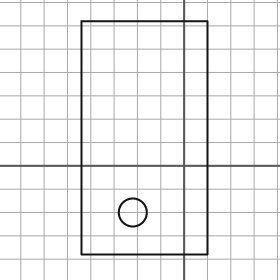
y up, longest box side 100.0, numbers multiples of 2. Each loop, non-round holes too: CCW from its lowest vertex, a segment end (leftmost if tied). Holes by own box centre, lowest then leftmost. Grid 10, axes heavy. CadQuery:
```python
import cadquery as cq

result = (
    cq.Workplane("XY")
    .moveTo(-44.0, -38.0)
    .lineTo(10.0, -38.0)
    .lineTo(10.0, 62.0)
    .lineTo(-44.0, 62.0)
    .close()
    .moveTo(-22.0, -20.0)
    .circle(6.0)
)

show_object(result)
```